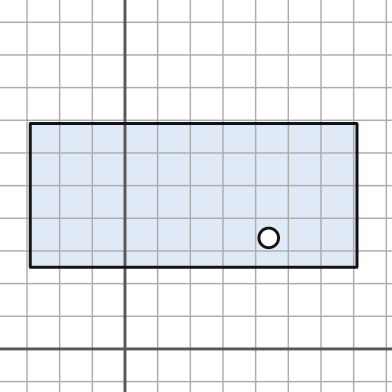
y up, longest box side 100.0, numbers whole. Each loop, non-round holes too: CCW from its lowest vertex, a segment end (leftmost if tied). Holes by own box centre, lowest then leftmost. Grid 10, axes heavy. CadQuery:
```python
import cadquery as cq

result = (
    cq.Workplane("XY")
    .moveTo(-29.0, 25.0)
    .lineTo(71.0, 25.0)
    .lineTo(71.0, 69.0)
    .lineTo(-29.0, 69.0)
    .close()
    .moveTo(44.0, 34.0)
    .circle(3.0)
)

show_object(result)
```